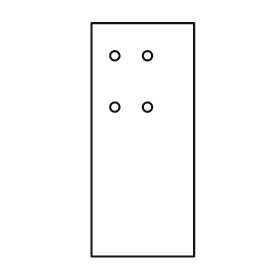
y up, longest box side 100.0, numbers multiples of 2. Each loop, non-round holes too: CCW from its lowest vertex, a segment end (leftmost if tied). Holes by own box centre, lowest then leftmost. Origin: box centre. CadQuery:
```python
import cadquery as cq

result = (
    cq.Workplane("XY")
    .moveTo(-22.0, -50.0)
    .lineTo(22.0, -50.0)
    .lineTo(22.0, 50.0)
    .lineTo(-22.0, 50.0)
    .close()
    .moveTo(-12.0, 14.0)
    .circle(2.0)
    .moveTo(2.0, 14.0)
    .circle(2.0)
    .moveTo(-12.0, 36.0)
    .circle(2.0)
    .moveTo(2.0, 36.0)
    .circle(2.0)
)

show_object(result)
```